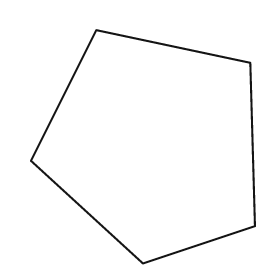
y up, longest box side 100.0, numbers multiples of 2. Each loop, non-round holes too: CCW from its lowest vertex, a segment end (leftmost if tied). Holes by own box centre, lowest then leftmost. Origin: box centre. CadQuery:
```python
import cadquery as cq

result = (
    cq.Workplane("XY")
    .moveTo(0.0, -50.0)
    .lineTo(48.0, -34.0)
    .lineTo(46.0, 36.0)
    .lineTo(-20.0, 50.0)
    .lineTo(-48.0, -6.0)
    .close()
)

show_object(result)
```